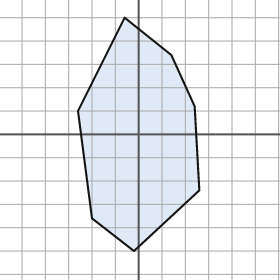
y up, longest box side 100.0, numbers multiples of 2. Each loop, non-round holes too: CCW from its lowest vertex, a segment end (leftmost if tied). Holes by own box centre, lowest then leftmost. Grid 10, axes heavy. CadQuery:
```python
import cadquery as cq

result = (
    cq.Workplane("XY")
    .moveTo(-2.0, -50.0)
    .lineTo(26.0, -24.0)
    .lineTo(24.0, 12.0)
    .lineTo(14.0, 34.0)
    .lineTo(-6.0, 50.0)
    .lineTo(-26.0, 10.0)
    .lineTo(-20.0, -36.0)
    .close()
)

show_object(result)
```